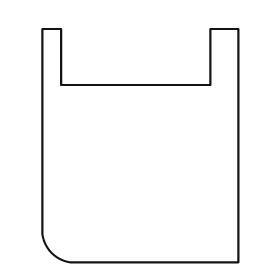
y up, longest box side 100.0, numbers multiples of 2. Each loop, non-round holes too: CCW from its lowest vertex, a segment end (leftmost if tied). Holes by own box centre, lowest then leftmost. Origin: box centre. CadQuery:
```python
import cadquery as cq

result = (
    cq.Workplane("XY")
    .moveTo(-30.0, -50.0)
    .lineTo(42.0, -50.0)
    .lineTo(42.0, 50.0)
    .lineTo(30.0, 50.0)
    .lineTo(30.0, 26.0)
    .lineTo(-34.0, 26.0)
    .lineTo(-34.0, 50.0)
    .lineTo(-42.0, 50.0)
    .lineTo(-42.0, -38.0)
    .threePointArc((-38.0, -46.0), (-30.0, -50.0))
    .close()
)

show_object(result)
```